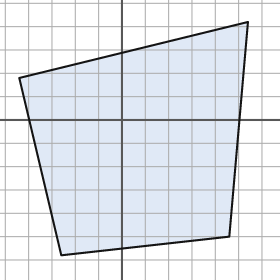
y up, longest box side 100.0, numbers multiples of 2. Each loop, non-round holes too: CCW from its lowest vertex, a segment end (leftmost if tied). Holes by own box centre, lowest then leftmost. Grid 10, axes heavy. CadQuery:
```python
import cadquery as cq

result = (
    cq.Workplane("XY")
    .moveTo(-26.0, -58.0)
    .lineTo(46.0, -50.0)
    .lineTo(54.0, 42.0)
    .lineTo(-44.0, 18.0)
    .close()
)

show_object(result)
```